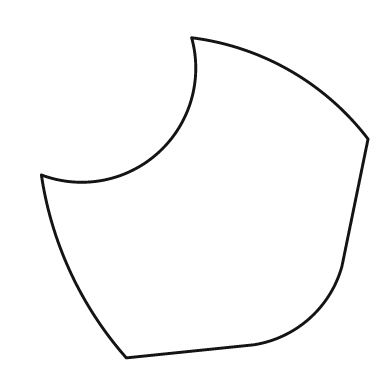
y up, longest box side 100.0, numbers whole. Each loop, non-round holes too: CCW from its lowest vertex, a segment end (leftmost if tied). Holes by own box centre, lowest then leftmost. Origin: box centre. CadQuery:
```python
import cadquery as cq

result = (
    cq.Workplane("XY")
    .moveTo(-24.0, -49.0)
    .lineTo(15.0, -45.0)
    .threePointArc((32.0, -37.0), (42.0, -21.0))
    .lineTo(50.0, 18.0)
    .threePointArc((26.0, 39.0), (-4.0, 49.0))
    .threePointArc((-14.0, 14.0), (-50.0, 7.0))
    .threePointArc((-41.0, -23.0), (-24.0, -49.0))
    .close()
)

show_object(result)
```